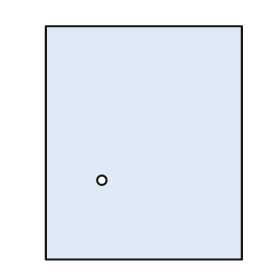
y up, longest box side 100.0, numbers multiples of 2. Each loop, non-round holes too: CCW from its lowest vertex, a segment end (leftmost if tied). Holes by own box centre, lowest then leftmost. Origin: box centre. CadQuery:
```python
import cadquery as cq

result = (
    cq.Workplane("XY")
    .moveTo(-42.0, -50.0)
    .lineTo(42.0, -50.0)
    .lineTo(42.0, 50.0)
    .lineTo(-42.0, 50.0)
    .close()
    .moveTo(-18.0, -16.0)
    .circle(2.0)
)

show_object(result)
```